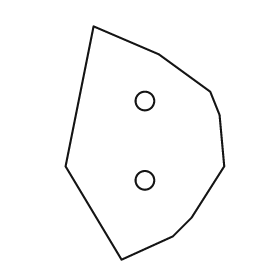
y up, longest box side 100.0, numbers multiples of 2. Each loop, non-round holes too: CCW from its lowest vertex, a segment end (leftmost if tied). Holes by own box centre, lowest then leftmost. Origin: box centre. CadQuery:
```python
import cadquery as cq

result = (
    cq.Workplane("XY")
    .moveTo(-10.0, -50.0)
    .lineTo(12.0, -40.0)
    .lineTo(20.0, -32.0)
    .lineTo(34.0, -10.0)
    .lineTo(32.0, 12.0)
    .lineTo(28.0, 22.0)
    .lineTo(6.0, 38.0)
    .lineTo(-22.0, 50.0)
    .lineTo(-34.0, -10.0)
    .close()
    .moveTo(0.0, -16.0)
    .circle(4.0)
    .moveTo(0.0, 18.0)
    .circle(4.0)
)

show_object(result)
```